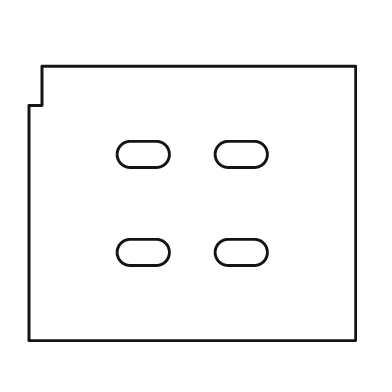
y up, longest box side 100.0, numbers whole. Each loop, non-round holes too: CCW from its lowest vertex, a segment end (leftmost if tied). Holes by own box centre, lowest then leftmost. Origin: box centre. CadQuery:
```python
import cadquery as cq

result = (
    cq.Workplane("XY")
    .moveTo(-50.0, -42.0)
    .lineTo(50.0, -42.0)
    .lineTo(50.0, 42.0)
    .lineTo(-46.0, 42.0)
    .lineTo(-46.0, 30.0)
    .lineTo(-50.0, 30.0)
    .close()
    .moveTo(-19.0, -19.0)
    .lineTo(-11.0, -19.0)
    .threePointArc((-7.0, -15.0), (-11.0, -11.0))
    .lineTo(-19.0, -11.0)
    .threePointArc((-23.0, -15.0), (-19.0, -19.0))
    .close()
    .moveTo(11.0, -19.0)
    .lineTo(19.0, -19.0)
    .threePointArc((23.0, -15.0), (19.0, -11.0))
    .lineTo(11.0, -11.0)
    .threePointArc((7.0, -15.0), (11.0, -19.0))
    .close()
    .moveTo(-19.0, 11.0)
    .lineTo(-11.0, 11.0)
    .threePointArc((-7.0, 15.0), (-11.0, 19.0))
    .lineTo(-19.0, 19.0)
    .threePointArc((-23.0, 15.0), (-19.0, 11.0))
    .close()
    .moveTo(11.0, 11.0)
    .lineTo(19.0, 11.0)
    .threePointArc((23.0, 15.0), (19.0, 19.0))
    .lineTo(11.0, 19.0)
    .threePointArc((7.0, 15.0), (11.0, 11.0))
    .close()
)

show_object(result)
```